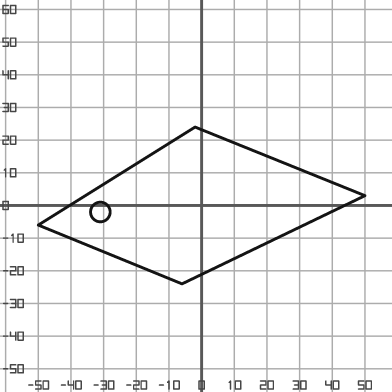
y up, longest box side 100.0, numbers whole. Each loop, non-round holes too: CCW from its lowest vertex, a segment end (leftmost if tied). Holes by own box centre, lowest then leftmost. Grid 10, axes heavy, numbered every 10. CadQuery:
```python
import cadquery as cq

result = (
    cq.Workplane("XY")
    .moveTo(-6.0, -24.0)
    .lineTo(50.0, 3.0)
    .lineTo(-2.0, 24.0)
    .lineTo(-50.0, -6.0)
    .close()
    .moveTo(-31.0, -2.0)
    .circle(3.0)
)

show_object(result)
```